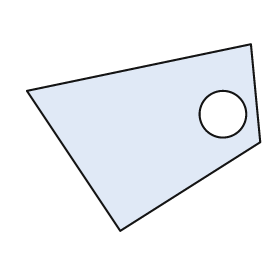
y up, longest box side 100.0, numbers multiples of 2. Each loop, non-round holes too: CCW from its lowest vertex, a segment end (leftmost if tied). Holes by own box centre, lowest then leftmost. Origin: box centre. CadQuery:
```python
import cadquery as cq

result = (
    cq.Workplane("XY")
    .moveTo(-10.0, -40.0)
    .lineTo(50.0, -2.0)
    .lineTo(46.0, 40.0)
    .lineTo(-50.0, 20.0)
    .close()
    .moveTo(34.0, 10.0)
    .circle(10.0)
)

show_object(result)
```